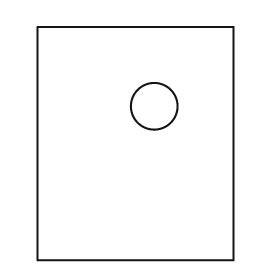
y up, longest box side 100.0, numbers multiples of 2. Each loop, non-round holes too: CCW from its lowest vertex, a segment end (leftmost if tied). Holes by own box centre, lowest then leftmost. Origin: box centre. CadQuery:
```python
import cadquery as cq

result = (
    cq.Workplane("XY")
    .moveTo(-42.0, -50.0)
    .lineTo(42.0, -50.0)
    .lineTo(42.0, 50.0)
    .lineTo(-42.0, 50.0)
    .close()
    .moveTo(8.0, 16.0)
    .circle(10.0)
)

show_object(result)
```